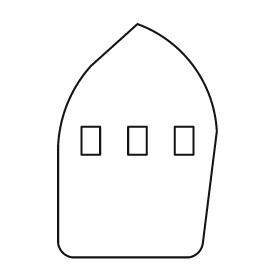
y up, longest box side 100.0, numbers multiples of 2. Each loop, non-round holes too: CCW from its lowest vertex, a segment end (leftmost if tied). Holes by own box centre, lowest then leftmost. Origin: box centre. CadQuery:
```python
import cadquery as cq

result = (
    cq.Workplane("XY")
    .moveTo(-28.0, -50.0)
    .lineTo(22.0, -50.0)
    .threePointArc((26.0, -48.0), (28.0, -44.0))
    .lineTo(34.0, 4.0)
    .threePointArc((24.0, 32.0), (0.0, 50.0))
    .lineTo(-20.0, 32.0)
    .threePointArc((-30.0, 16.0), (-34.0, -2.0))
    .lineTo(-34.0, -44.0)
    .threePointArc((-32.0, -48.0), (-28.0, -50.0))
    .close()
    .moveTo(-24.0, -6.0)
    .lineTo(-16.0, -6.0)
    .lineTo(-16.0, 6.0)
    .lineTo(-24.0, 6.0)
    .close()
    .moveTo(-4.0, -6.0)
    .lineTo(4.0, -6.0)
    .lineTo(4.0, 6.0)
    .lineTo(-4.0, 6.0)
    .close()
    .moveTo(16.0, -6.0)
    .lineTo(24.0, -6.0)
    .lineTo(24.0, 6.0)
    .lineTo(16.0, 6.0)
    .close()
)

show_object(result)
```